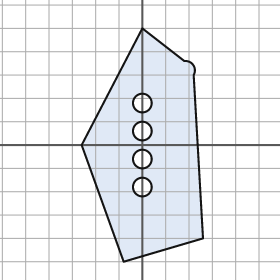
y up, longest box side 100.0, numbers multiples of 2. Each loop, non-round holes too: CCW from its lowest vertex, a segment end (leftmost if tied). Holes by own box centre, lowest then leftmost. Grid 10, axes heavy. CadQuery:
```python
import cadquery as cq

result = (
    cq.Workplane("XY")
    .moveTo(-8.0, -50.0)
    .lineTo(26.0, -40.0)
    .lineTo(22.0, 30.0)
    .threePointArc((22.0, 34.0), (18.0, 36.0))
    .lineTo(0.0, 50.0)
    .lineTo(-26.0, 0.0)
    .close()
    .moveTo(0.0, -18.0)
    .circle(4.0)
    .moveTo(0.0, -6.0)
    .circle(4.0)
    .moveTo(0.0, 6.0)
    .circle(4.0)
    .moveTo(0.0, 18.0)
    .circle(4.0)
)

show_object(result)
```